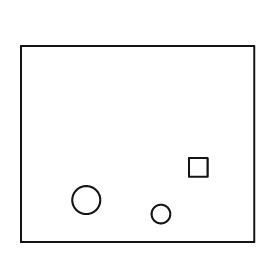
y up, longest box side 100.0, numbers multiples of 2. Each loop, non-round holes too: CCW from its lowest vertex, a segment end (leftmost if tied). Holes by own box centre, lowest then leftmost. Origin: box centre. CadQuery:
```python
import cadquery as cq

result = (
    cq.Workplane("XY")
    .moveTo(-50.0, -42.0)
    .lineTo(50.0, -42.0)
    .lineTo(50.0, 42.0)
    .lineTo(-50.0, 42.0)
    .close()
    .moveTo(10.0, -30.0)
    .circle(4.0)
    .moveTo(-22.0, -24.0)
    .circle(6.0)
    .moveTo(22.0, -14.0)
    .lineTo(30.0, -14.0)
    .lineTo(30.0, -6.0)
    .lineTo(22.0, -6.0)
    .close()
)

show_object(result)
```